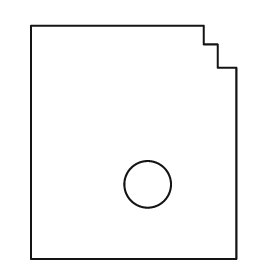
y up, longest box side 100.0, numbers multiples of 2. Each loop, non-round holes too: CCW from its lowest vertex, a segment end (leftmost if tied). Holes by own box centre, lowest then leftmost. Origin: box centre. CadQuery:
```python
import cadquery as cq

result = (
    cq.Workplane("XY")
    .moveTo(-44.0, -50.0)
    .lineTo(44.0, -50.0)
    .lineTo(44.0, 32.0)
    .lineTo(36.0, 32.0)
    .lineTo(36.0, 42.0)
    .lineTo(30.0, 42.0)
    .lineTo(30.0, 50.0)
    .lineTo(-44.0, 50.0)
    .close()
    .moveTo(6.0, -18.0)
    .circle(10.0)
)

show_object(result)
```